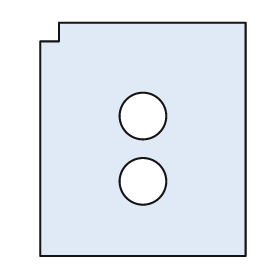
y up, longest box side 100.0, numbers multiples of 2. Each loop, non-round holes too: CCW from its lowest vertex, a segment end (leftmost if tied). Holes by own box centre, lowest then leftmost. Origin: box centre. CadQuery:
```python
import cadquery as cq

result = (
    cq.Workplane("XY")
    .moveTo(-44.0, -50.0)
    .lineTo(44.0, -50.0)
    .lineTo(44.0, 50.0)
    .lineTo(-36.0, 50.0)
    .lineTo(-36.0, 42.0)
    .lineTo(-44.0, 42.0)
    .close()
    .moveTo(0.0, -18.0)
    .circle(10.0)
    .moveTo(0.0, 10.0)
    .circle(10.0)
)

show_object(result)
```